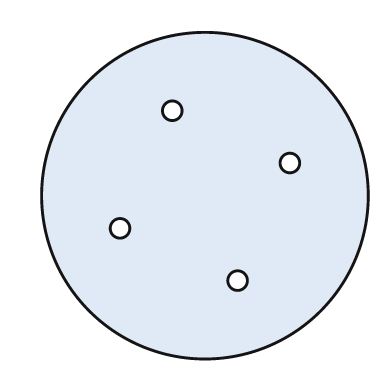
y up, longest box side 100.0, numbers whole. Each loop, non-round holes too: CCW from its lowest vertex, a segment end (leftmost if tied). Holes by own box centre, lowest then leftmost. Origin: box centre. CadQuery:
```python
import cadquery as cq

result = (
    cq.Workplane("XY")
    .moveTo(0.0, 0.0)
    .circle(50.0)
    .moveTo(10.0, -26.0)
    .circle(3.0)
    .moveTo(-26.0, -10.0)
    .circle(3.0)
    .moveTo(26.0, 10.0)
    .circle(3.0)
    .moveTo(-10.0, 26.0)
    .circle(3.0)
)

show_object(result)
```